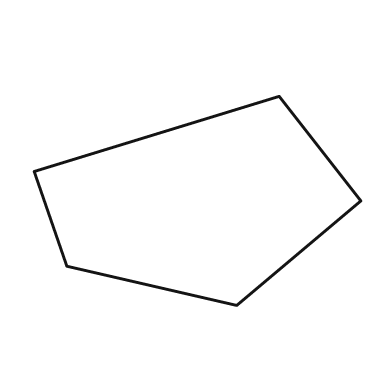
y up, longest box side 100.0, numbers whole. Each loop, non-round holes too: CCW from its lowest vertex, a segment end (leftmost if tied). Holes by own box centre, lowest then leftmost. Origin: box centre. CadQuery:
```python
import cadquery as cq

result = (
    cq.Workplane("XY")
    .moveTo(12.0, -32.0)
    .lineTo(50.0, 0.0)
    .lineTo(25.0, 32.0)
    .lineTo(-50.0, 9.0)
    .lineTo(-40.0, -20.0)
    .close()
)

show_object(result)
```